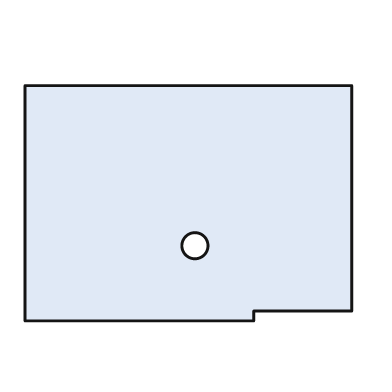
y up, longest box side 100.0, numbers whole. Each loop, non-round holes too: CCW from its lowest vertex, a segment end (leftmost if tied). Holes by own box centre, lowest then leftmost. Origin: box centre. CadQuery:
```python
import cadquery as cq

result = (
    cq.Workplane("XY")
    .moveTo(-50.0, -36.0)
    .lineTo(20.0, -36.0)
    .lineTo(20.0, -33.0)
    .lineTo(50.0, -33.0)
    .lineTo(50.0, 36.0)
    .lineTo(-50.0, 36.0)
    .close()
    .moveTo(2.0, -13.0)
    .circle(4.0)
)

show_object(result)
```